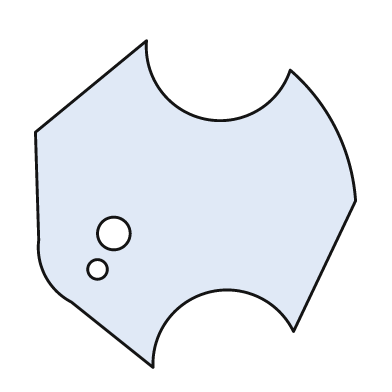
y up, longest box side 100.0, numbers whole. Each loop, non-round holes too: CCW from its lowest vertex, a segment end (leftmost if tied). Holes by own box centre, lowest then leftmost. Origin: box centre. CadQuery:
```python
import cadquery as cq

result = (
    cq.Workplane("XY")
    .moveTo(-13.0, -50.0)
    .threePointArc((4.0, -27.0), (30.0, -39.0))
    .lineTo(49.0, 1.0)
    .threePointArc((43.0, 23.0), (29.0, 41.0))
    .threePointArc((3.0, 26.0), (-15.0, 50.0))
    .lineTo(-49.0, 22.0)
    .lineTo(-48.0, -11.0)
    .threePointArc((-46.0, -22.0), (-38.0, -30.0))
    .close()
    .moveTo(-30.0, -20.0)
    .circle(3.0)
    .moveTo(-25.0, -9.0)
    .circle(5.0)
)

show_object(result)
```